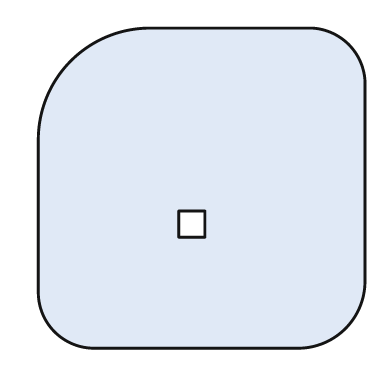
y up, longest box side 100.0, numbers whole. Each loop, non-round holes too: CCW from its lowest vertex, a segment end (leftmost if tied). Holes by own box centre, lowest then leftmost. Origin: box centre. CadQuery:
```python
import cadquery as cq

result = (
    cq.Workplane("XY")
    .moveTo(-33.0, -49.0)
    .lineTo(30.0, -49.0)
    .threePointArc((44.0, -43.0), (50.0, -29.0))
    .lineTo(50.0, 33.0)
    .threePointArc((45.0, 44.0), (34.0, 49.0))
    .lineTo(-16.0, 49.0)
    .threePointArc((-40.0, 39.0), (-50.0, 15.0))
    .lineTo(-50.0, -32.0)
    .threePointArc((-45.0, -44.0), (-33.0, -49.0))
    .close()
    .moveTo(-7.0, -15.0)
    .lineTo(1.0, -15.0)
    .lineTo(1.0, -7.0)
    .lineTo(-7.0, -7.0)
    .close()
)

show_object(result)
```